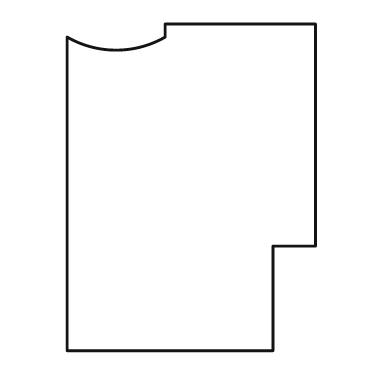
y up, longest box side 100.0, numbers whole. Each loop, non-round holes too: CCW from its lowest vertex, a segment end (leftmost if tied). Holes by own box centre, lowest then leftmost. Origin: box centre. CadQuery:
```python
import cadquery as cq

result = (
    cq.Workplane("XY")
    .moveTo(-38.0, -50.0)
    .lineTo(25.0, -50.0)
    .lineTo(25.0, -18.0)
    .lineTo(38.0, -18.0)
    .lineTo(38.0, 50.0)
    .lineTo(-8.0, 50.0)
    .lineTo(-8.0, 46.0)
    .threePointArc((-23.0, 42.0), (-38.0, 46.0))
    .close()
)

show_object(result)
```